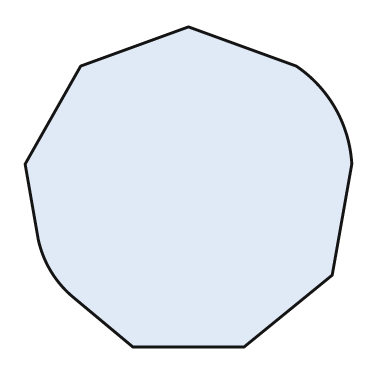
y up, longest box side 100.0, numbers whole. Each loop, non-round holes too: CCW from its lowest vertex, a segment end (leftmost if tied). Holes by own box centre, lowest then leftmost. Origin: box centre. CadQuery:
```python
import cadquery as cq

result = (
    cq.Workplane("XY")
    .moveTo(-17.0, -49.0)
    .lineTo(17.0, -49.0)
    .lineTo(44.0, -27.0)
    .lineTo(50.0, 7.0)
    .threePointArc((45.0, 24.0), (33.0, 37.0))
    .lineTo(0.0, 49.0)
    .lineTo(-33.0, 37.0)
    .lineTo(-50.0, 7.0)
    .lineTo(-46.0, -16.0)
    .threePointArc((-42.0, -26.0), (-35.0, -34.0))
    .close()
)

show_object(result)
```